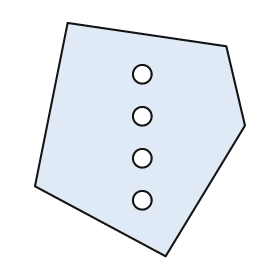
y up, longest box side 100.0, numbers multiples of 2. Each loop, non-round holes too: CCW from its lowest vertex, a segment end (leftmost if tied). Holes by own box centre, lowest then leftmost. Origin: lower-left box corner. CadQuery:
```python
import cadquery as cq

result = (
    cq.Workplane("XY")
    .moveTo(56.0, 0.0)
    .lineTo(90.0, 56.0)
    .lineTo(82.0, 90.0)
    .lineTo(14.0, 100.0)
    .lineTo(0.0, 30.0)
    .close()
    .moveTo(46.0, 24.0)
    .circle(4.0)
    .moveTo(46.0, 42.0)
    .circle(4.0)
    .moveTo(46.0, 60.0)
    .circle(4.0)
    .moveTo(46.0, 78.0)
    .circle(4.0)
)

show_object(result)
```